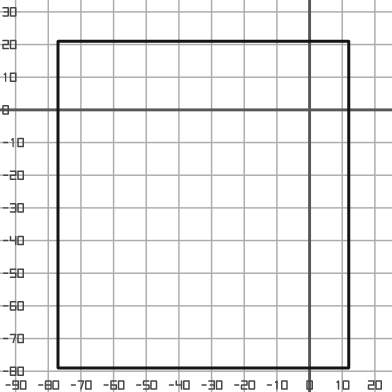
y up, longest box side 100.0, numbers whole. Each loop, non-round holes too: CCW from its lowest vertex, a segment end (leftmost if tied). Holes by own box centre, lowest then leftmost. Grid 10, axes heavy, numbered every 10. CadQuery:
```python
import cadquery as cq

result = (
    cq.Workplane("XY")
    .moveTo(-77.0, -79.0)
    .lineTo(12.0, -79.0)
    .lineTo(12.0, 21.0)
    .lineTo(-77.0, 21.0)
    .close()
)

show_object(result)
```